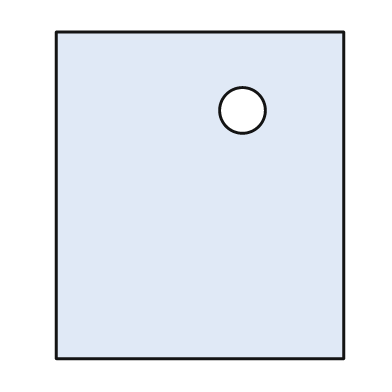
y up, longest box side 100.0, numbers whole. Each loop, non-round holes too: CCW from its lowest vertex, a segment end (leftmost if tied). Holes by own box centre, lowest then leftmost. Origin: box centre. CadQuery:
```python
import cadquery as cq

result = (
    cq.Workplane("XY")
    .moveTo(-44.0, -50.0)
    .lineTo(44.0, -50.0)
    .lineTo(44.0, 50.0)
    .lineTo(-44.0, 50.0)
    .close()
    .moveTo(13.0, 26.0)
    .circle(7.0)
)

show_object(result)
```